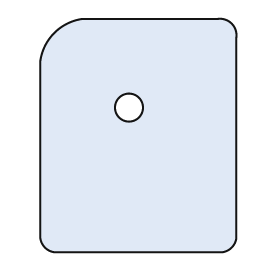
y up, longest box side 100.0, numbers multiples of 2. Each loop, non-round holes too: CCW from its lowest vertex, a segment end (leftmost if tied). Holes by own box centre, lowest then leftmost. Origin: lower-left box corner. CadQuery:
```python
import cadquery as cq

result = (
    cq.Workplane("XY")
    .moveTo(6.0, 0.0)
    .lineTo(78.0, 0.0)
    .threePointArc((82.0, 2.0), (84.0, 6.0))
    .lineTo(84.0, 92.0)
    .threePointArc((82.0, 98.0), (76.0, 100.0))
    .lineTo(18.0, 100.0)
    .threePointArc((6.0, 94.0), (0.0, 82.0))
    .lineTo(0.0, 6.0)
    .threePointArc((2.0, 2.0), (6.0, 0.0))
    .close()
    .moveTo(38.0, 62.0)
    .circle(6.0)
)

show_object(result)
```